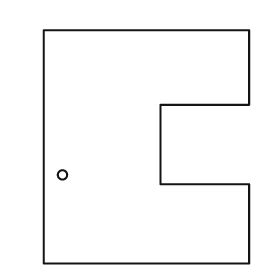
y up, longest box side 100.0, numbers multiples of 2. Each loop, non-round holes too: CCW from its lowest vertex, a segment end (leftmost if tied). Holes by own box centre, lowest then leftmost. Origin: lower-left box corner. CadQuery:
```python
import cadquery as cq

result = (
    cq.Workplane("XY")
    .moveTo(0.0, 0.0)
    .lineTo(88.0, 0.0)
    .lineTo(88.0, 34.0)
    .lineTo(50.0, 34.0)
    .lineTo(50.0, 68.0)
    .lineTo(88.0, 68.0)
    .lineTo(88.0, 100.0)
    .lineTo(0.0, 100.0)
    .close()
    .moveTo(8.0, 38.0)
    .circle(2.0)
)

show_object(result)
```